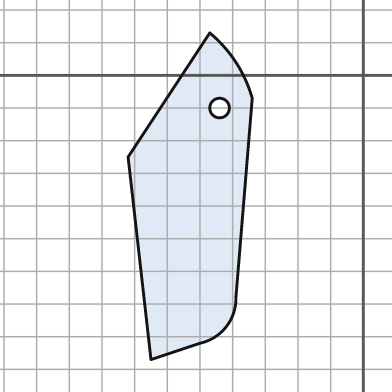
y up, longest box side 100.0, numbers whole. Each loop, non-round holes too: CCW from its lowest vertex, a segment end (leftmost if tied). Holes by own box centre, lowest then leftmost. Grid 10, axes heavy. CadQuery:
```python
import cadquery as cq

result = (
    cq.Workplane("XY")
    .moveTo(-65.0, -87.0)
    .lineTo(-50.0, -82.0)
    .threePointArc((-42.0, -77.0), (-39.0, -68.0))
    .lineTo(-34.0, -7.0)
    .threePointArc((-39.0, 4.0), (-47.0, 13.0))
    .lineTo(-72.0, -25.0)
    .close()
    .moveTo(-44.0, -10.0)
    .circle(3.0)
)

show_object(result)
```